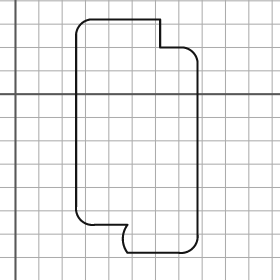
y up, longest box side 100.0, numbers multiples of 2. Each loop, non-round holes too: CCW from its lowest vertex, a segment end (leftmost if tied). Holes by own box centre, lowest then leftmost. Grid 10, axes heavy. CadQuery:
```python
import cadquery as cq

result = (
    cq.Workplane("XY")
    .moveTo(48.0, -68.0)
    .lineTo(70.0, -68.0)
    .threePointArc((76.0, -66.0), (78.0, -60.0))
    .lineTo(78.0, 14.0)
    .threePointArc((76.0, 18.0), (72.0, 20.0))
    .lineTo(62.0, 20.0)
    .lineTo(62.0, 32.0)
    .lineTo(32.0, 32.0)
    .threePointArc((28.0, 30.0), (26.0, 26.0))
    .lineTo(26.0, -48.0)
    .threePointArc((28.0, -54.0), (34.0, -56.0))
    .lineTo(48.0, -56.0)
    .threePointArc((46.0, -62.0), (48.0, -68.0))
    .close()
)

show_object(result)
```